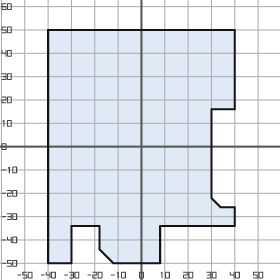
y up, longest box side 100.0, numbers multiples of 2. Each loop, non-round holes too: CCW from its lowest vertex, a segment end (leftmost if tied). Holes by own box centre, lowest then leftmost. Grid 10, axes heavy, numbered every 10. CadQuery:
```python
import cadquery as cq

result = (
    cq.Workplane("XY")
    .moveTo(-40.0, -50.0)
    .lineTo(-30.0, -50.0)
    .lineTo(-30.0, -34.0)
    .lineTo(-18.0, -34.0)
    .lineTo(-18.0, -44.0)
    .lineTo(-12.0, -50.0)
    .lineTo(8.0, -50.0)
    .lineTo(8.0, -34.0)
    .lineTo(40.0, -34.0)
    .lineTo(40.0, -26.0)
    .lineTo(34.0, -26.0)
    .lineTo(30.0, -22.0)
    .lineTo(30.0, 16.0)
    .lineTo(40.0, 16.0)
    .lineTo(40.0, 50.0)
    .lineTo(-40.0, 50.0)
    .close()
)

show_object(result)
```